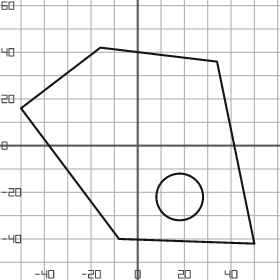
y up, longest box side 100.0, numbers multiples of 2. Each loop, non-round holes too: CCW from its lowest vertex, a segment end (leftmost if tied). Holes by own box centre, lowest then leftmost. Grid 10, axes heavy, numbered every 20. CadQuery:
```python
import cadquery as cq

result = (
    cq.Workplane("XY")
    .moveTo(50.0, -42.0)
    .lineTo(34.0, 36.0)
    .lineTo(-16.0, 42.0)
    .lineTo(-50.0, 16.0)
    .lineTo(-8.0, -40.0)
    .close()
    .moveTo(18.0, -22.0)
    .circle(10.0)
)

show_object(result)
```